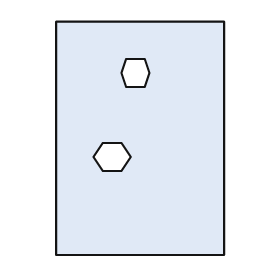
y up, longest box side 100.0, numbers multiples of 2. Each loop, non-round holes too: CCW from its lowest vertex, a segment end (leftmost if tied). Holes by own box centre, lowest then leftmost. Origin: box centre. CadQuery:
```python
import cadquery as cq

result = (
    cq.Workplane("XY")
    .moveTo(-36.0, -50.0)
    .lineTo(36.0, -50.0)
    .lineTo(36.0, 50.0)
    .lineTo(-36.0, 50.0)
    .close()
    .moveTo(-16.0, -14.0)
    .lineTo(-8.0, -14.0)
    .lineTo(-4.0, -8.0)
    .lineTo(-8.0, -2.0)
    .lineTo(-16.0, -2.0)
    .lineTo(-20.0, -8.0)
    .close()
    .moveTo(-6.0, 22.0)
    .lineTo(2.0, 22.0)
    .lineTo(4.0, 28.0)
    .lineTo(2.0, 34.0)
    .lineTo(-6.0, 34.0)
    .lineTo(-8.0, 28.0)
    .close()
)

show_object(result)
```